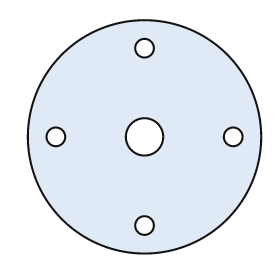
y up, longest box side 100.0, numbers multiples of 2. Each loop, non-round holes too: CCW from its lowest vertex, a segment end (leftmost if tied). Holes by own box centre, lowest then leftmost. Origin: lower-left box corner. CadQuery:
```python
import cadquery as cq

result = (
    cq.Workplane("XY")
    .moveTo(50.0, 50.0)
    .circle(50.0)
    .moveTo(50.0, 12.0)
    .circle(4.0)
    .moveTo(12.0, 50.0)
    .circle(4.0)
    .moveTo(50.0, 50.0)
    .circle(8.0)
    .moveTo(88.0, 50.0)
    .circle(4.0)
    .moveTo(50.0, 88.0)
    .circle(4.0)
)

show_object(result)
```